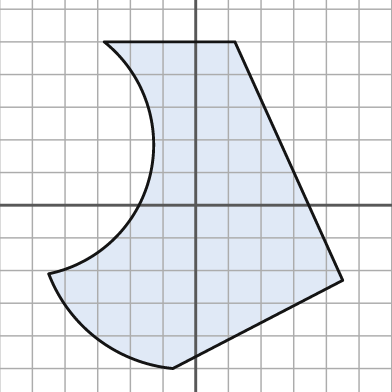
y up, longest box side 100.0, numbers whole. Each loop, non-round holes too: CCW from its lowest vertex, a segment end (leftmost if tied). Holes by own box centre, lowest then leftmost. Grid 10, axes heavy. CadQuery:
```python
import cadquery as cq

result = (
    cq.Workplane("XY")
    .moveTo(-7.0, -50.0)
    .lineTo(45.0, -23.0)
    .lineTo(12.0, 50.0)
    .lineTo(-28.0, 50.0)
    .threePointArc((-14.0, 9.0), (-45.0, -21.0))
    .threePointArc((-30.0, -41.0), (-7.0, -50.0))
    .close()
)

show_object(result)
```